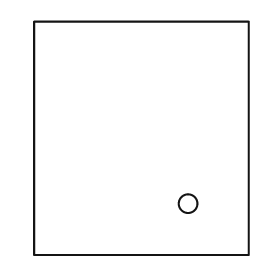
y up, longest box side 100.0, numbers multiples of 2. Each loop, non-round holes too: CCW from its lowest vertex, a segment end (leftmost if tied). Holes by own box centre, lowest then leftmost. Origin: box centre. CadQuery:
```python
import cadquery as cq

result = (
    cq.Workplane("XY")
    .moveTo(-46.0, -50.0)
    .lineTo(46.0, -50.0)
    .lineTo(46.0, 50.0)
    .lineTo(-46.0, 50.0)
    .close()
    .moveTo(20.0, -28.0)
    .circle(4.0)
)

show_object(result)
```